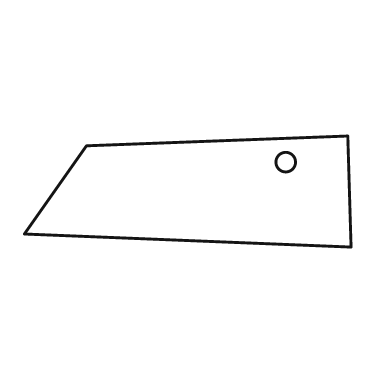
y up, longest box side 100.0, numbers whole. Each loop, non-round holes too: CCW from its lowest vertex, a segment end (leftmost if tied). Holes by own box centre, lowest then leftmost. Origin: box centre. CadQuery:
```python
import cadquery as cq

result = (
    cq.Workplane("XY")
    .moveTo(50.0, -17.0)
    .lineTo(49.0, 17.0)
    .lineTo(-31.0, 14.0)
    .lineTo(-50.0, -13.0)
    .close()
    .moveTo(30.0, 9.0)
    .circle(3.0)
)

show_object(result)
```